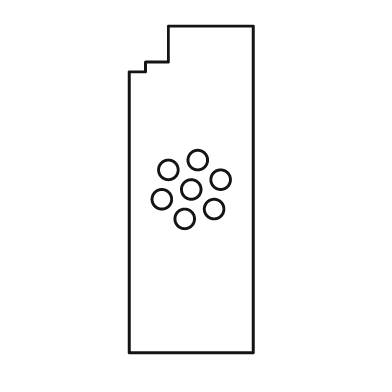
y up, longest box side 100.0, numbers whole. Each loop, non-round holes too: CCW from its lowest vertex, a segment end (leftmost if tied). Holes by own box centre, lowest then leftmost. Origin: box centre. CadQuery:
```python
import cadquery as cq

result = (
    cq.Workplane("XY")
    .moveTo(-19.0, -50.0)
    .lineTo(19.0, -50.0)
    .lineTo(19.0, 50.0)
    .lineTo(-7.0, 50.0)
    .lineTo(-7.0, 39.0)
    .lineTo(-14.0, 39.0)
    .lineTo(-14.0, 36.0)
    .lineTo(-19.0, 36.0)
    .close()
    .moveTo(-2.0, -9.0)
    .circle(3.0)
    .moveTo(7.0, -6.0)
    .circle(3.0)
    .moveTo(-9.0, -3.0)
    .circle(3.0)
    .moveTo(0.0, 0.0)
    .circle(3.0)
    .moveTo(9.0, 3.0)
    .circle(3.0)
    .moveTo(-7.0, 6.0)
    .circle(3.0)
    .moveTo(2.0, 9.0)
    .circle(3.0)
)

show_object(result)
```